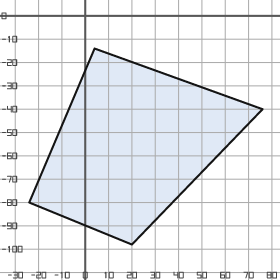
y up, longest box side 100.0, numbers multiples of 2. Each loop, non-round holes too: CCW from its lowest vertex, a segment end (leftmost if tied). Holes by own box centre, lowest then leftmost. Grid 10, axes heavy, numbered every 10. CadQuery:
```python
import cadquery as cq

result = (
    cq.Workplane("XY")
    .moveTo(20.0, -98.0)
    .lineTo(76.0, -40.0)
    .lineTo(4.0, -14.0)
    .lineTo(-24.0, -80.0)
    .close()
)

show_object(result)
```